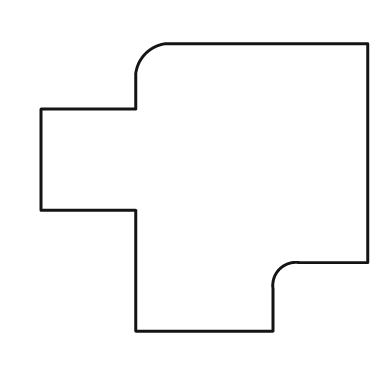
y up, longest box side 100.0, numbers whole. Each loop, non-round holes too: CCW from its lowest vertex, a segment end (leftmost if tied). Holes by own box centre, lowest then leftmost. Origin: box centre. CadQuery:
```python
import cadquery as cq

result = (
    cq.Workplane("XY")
    .moveTo(-21.0, -44.0)
    .lineTo(21.0, -44.0)
    .lineTo(21.0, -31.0)
    .threePointArc((23.0, -25.0), (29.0, -23.0))
    .lineTo(50.0, -23.0)
    .lineTo(50.0, 44.0)
    .lineTo(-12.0, 44.0)
    .threePointArc((-18.0, 41.0), (-21.0, 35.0))
    .lineTo(-21.0, 24.0)
    .lineTo(-50.0, 24.0)
    .lineTo(-50.0, -7.0)
    .lineTo(-21.0, -7.0)
    .close()
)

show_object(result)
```